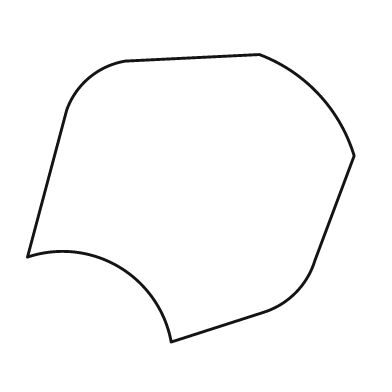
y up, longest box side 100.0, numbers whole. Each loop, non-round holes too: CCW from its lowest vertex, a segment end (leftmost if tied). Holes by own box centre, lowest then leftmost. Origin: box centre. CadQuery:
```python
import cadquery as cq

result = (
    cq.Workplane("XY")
    .moveTo(-6.0, -44.0)
    .lineTo(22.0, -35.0)
    .threePointArc((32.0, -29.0), (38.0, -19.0))
    .lineTo(50.0, 13.0)
    .threePointArc((39.0, 32.0), (21.0, 44.0))
    .lineTo(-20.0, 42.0)
    .threePointArc((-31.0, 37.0), (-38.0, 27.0))
    .lineTo(-50.0, -18.0)
    .threePointArc((-22.0, -21.0), (-6.0, -44.0))
    .close()
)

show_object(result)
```